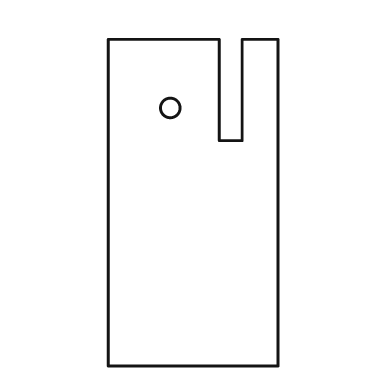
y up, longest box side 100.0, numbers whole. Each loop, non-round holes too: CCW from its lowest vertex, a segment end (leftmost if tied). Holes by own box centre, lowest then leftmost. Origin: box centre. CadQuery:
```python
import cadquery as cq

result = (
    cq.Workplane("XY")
    .moveTo(-26.0, -50.0)
    .lineTo(26.0, -50.0)
    .lineTo(26.0, 50.0)
    .lineTo(15.0, 50.0)
    .lineTo(15.0, 19.0)
    .lineTo(8.0, 19.0)
    .lineTo(8.0, 50.0)
    .lineTo(-26.0, 50.0)
    .close()
    .moveTo(-7.0, 29.0)
    .circle(3.0)
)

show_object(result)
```